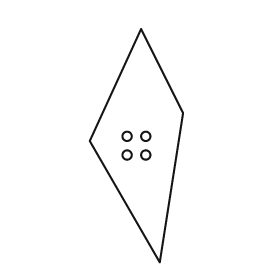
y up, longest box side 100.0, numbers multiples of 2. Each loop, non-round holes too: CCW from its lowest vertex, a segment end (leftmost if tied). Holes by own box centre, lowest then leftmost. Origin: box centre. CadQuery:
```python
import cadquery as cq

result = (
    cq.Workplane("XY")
    .moveTo(10.0, -50.0)
    .lineTo(20.0, 14.0)
    .lineTo(2.0, 50.0)
    .lineTo(-20.0, 2.0)
    .close()
    .moveTo(-4.0, -4.0)
    .circle(2.0)
    .moveTo(4.0, -4.0)
    .circle(2.0)
    .moveTo(-4.0, 4.0)
    .circle(2.0)
    .moveTo(4.0, 4.0)
    .circle(2.0)
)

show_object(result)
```